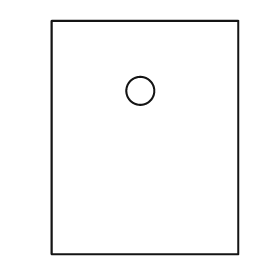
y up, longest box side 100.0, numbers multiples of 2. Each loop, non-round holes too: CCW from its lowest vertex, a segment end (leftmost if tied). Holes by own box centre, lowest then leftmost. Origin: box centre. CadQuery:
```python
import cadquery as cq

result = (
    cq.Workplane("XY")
    .moveTo(-40.0, -50.0)
    .lineTo(40.0, -50.0)
    .lineTo(40.0, 50.0)
    .lineTo(-40.0, 50.0)
    .close()
    .moveTo(-2.0, 20.0)
    .circle(6.0)
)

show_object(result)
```